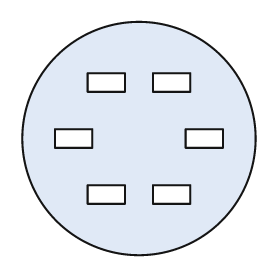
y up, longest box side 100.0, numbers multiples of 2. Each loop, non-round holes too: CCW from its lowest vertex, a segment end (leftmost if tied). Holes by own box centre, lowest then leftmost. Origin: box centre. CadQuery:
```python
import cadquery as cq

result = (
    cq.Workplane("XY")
    .moveTo(0.0, 0.0)
    .circle(50.0)
    .moveTo(-22.0, -28.0)
    .lineTo(-6.0, -28.0)
    .lineTo(-6.0, -20.0)
    .lineTo(-22.0, -20.0)
    .close()
    .moveTo(6.0, -28.0)
    .lineTo(22.0, -28.0)
    .lineTo(22.0, -20.0)
    .lineTo(6.0, -20.0)
    .close()
    .moveTo(-36.0, -4.0)
    .lineTo(-20.0, -4.0)
    .lineTo(-20.0, 4.0)
    .lineTo(-36.0, 4.0)
    .close()
    .moveTo(20.0, -4.0)
    .lineTo(36.0, -4.0)
    .lineTo(36.0, 4.0)
    .lineTo(20.0, 4.0)
    .close()
    .moveTo(-22.0, 20.0)
    .lineTo(-6.0, 20.0)
    .lineTo(-6.0, 28.0)
    .lineTo(-22.0, 28.0)
    .close()
    .moveTo(6.0, 20.0)
    .lineTo(22.0, 20.0)
    .lineTo(22.0, 28.0)
    .lineTo(6.0, 28.0)
    .close()
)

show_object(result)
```